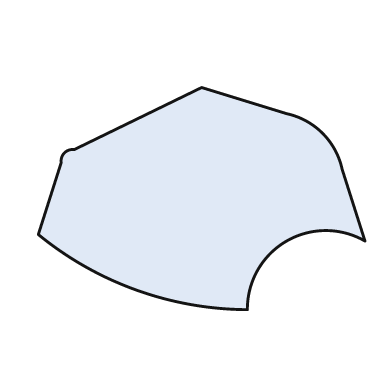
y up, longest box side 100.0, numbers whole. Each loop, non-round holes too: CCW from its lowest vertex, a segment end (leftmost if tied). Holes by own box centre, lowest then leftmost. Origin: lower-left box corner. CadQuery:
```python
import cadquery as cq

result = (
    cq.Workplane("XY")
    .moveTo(64.0, 0.0)
    .threePointArc((76.0, 21.0), (100.0, 21.0))
    .lineTo(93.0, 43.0)
    .threePointArc((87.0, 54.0), (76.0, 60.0))
    .lineTo(50.0, 68.0)
    .lineTo(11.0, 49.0)
    .threePointArc((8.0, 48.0), (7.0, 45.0))
    .lineTo(0.0, 23.0)
    .threePointArc((30.0, 6.0), (64.0, 0.0))
    .close()
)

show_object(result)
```